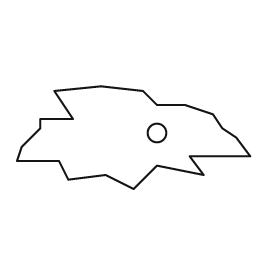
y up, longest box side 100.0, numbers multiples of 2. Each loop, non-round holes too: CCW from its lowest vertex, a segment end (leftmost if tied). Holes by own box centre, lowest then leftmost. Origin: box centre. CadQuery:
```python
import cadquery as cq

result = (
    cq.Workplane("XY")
    .moveTo(0.0, -22.0)
    .lineTo(10.0, -12.0)
    .lineTo(30.0, -16.0)
    .lineTo(24.0, -8.0)
    .lineTo(50.0, -8.0)
    .lineTo(44.0, 0.0)
    .lineTo(38.0, 4.0)
    .lineTo(34.0, 10.0)
    .lineTo(22.0, 14.0)
    .lineTo(10.0, 14.0)
    .lineTo(4.0, 20.0)
    .lineTo(-14.0, 22.0)
    .lineTo(-34.0, 20.0)
    .lineTo(-26.0, 8.0)
    .lineTo(-40.0, 8.0)
    .lineTo(-40.0, 4.0)
    .lineTo(-48.0, -4.0)
    .lineTo(-50.0, -10.0)
    .lineTo(-32.0, -10.0)
    .lineTo(-28.0, -18.0)
    .lineTo(-12.0, -16.0)
    .close()
    .moveTo(10.0, 2.0)
    .circle(4.0)
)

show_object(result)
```